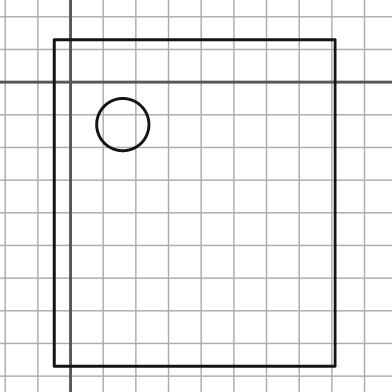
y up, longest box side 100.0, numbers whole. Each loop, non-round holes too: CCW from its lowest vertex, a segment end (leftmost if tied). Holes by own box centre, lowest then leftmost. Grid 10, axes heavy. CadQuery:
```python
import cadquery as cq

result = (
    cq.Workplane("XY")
    .moveTo(-5.0, -87.0)
    .lineTo(81.0, -87.0)
    .lineTo(81.0, 13.0)
    .lineTo(-5.0, 13.0)
    .close()
    .moveTo(16.0, -13.0)
    .circle(8.0)
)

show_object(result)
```